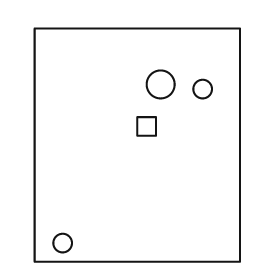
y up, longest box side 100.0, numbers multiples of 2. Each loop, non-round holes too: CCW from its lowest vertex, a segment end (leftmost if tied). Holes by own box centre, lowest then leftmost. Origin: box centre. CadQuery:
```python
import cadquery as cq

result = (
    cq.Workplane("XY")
    .moveTo(-44.0, -50.0)
    .lineTo(44.0, -50.0)
    .lineTo(44.0, 50.0)
    .lineTo(-44.0, 50.0)
    .close()
    .moveTo(-32.0, -42.0)
    .circle(4.0)
    .moveTo(0.0, 4.0)
    .lineTo(8.0, 4.0)
    .lineTo(8.0, 12.0)
    .lineTo(0.0, 12.0)
    .close()
    .moveTo(28.0, 24.0)
    .circle(4.0)
    .moveTo(10.0, 26.0)
    .circle(6.0)
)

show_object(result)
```